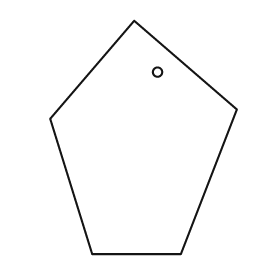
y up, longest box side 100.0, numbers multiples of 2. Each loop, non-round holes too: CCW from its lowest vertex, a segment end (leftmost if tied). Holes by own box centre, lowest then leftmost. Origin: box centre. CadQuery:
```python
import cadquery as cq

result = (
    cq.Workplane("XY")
    .moveTo(-22.0, -50.0)
    .lineTo(16.0, -50.0)
    .lineTo(40.0, 12.0)
    .lineTo(-4.0, 50.0)
    .lineTo(-40.0, 8.0)
    .close()
    .moveTo(6.0, 28.0)
    .circle(2.0)
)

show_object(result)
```